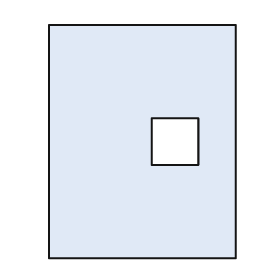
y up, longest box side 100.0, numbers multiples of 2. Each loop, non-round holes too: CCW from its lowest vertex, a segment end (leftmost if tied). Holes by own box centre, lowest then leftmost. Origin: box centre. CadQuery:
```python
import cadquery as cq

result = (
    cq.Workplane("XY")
    .moveTo(-40.0, -50.0)
    .lineTo(40.0, -50.0)
    .lineTo(40.0, 50.0)
    .lineTo(-40.0, 50.0)
    .close()
    .moveTo(4.0, -10.0)
    .lineTo(24.0, -10.0)
    .lineTo(24.0, 10.0)
    .lineTo(4.0, 10.0)
    .close()
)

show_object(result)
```